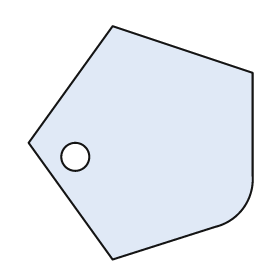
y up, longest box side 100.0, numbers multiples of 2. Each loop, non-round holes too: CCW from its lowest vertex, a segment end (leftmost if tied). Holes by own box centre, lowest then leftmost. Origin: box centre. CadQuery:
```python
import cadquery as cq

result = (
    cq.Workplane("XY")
    .moveTo(-12.0, -50.0)
    .lineTo(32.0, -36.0)
    .threePointArc((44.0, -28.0), (48.0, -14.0))
    .lineTo(48.0, 30.0)
    .lineTo(-12.0, 50.0)
    .lineTo(-48.0, 0.0)
    .close()
    .moveTo(-28.0, -6.0)
    .circle(6.0)
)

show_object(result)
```